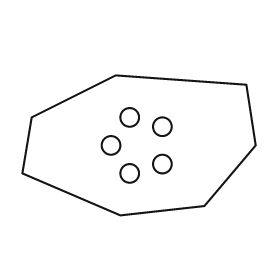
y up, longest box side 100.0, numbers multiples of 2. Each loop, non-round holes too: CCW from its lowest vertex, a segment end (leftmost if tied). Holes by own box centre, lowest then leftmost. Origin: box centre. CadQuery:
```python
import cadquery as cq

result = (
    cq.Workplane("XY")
    .moveTo(-8.0, -30.0)
    .lineTo(28.0, -26.0)
    .lineTo(50.0, 0.0)
    .lineTo(46.0, 26.0)
    .lineTo(-10.0, 30.0)
    .lineTo(-46.0, 12.0)
    .lineTo(-50.0, -12.0)
    .close()
    .moveTo(-4.0, -12.0)
    .circle(4.0)
    .moveTo(10.0, -8.0)
    .circle(4.0)
    .moveTo(-12.0, 0.0)
    .circle(4.0)
    .moveTo(10.0, 8.0)
    .circle(4.0)
    .moveTo(-4.0, 12.0)
    .circle(4.0)
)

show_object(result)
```